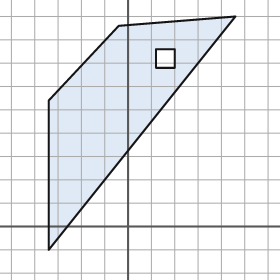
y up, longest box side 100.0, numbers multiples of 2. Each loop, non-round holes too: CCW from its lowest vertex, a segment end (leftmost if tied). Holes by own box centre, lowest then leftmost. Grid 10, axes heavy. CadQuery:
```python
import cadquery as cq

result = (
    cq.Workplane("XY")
    .moveTo(-34.0, -10.0)
    .lineTo(46.0, 90.0)
    .lineTo(-4.0, 86.0)
    .lineTo(-34.0, 54.0)
    .close()
    .moveTo(12.0, 68.0)
    .lineTo(20.0, 68.0)
    .lineTo(20.0, 76.0)
    .lineTo(12.0, 76.0)
    .close()
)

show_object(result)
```